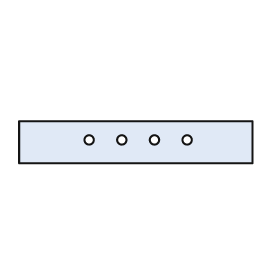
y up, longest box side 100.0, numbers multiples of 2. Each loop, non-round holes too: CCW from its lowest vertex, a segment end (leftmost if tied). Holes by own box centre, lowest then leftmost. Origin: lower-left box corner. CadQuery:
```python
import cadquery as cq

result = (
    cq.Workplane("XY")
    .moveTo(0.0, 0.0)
    .lineTo(100.0, 0.0)
    .lineTo(100.0, 18.0)
    .lineTo(0.0, 18.0)
    .close()
    .moveTo(30.0, 10.0)
    .circle(2.0)
    .moveTo(44.0, 10.0)
    .circle(2.0)
    .moveTo(58.0, 10.0)
    .circle(2.0)
    .moveTo(72.0, 10.0)
    .circle(2.0)
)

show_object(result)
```